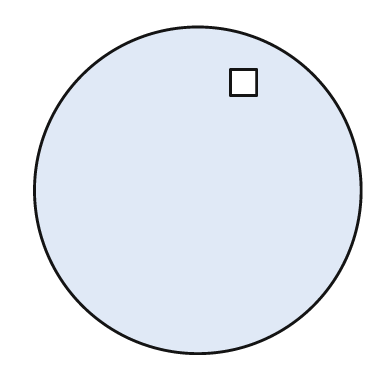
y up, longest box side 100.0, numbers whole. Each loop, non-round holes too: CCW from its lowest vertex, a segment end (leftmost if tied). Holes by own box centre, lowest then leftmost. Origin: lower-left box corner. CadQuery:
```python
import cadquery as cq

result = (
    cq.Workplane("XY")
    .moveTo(50.0, 50.0)
    .circle(50.0)
    .moveTo(60.0, 79.0)
    .lineTo(68.0, 79.0)
    .lineTo(68.0, 87.0)
    .lineTo(60.0, 87.0)
    .close()
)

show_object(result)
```